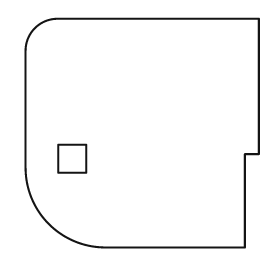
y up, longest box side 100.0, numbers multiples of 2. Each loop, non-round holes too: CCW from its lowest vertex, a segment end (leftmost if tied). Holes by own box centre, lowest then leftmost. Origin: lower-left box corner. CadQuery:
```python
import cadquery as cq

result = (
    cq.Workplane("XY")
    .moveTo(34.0, 0.0)
    .lineTo(94.0, 0.0)
    .lineTo(94.0, 40.0)
    .lineTo(100.0, 40.0)
    .lineTo(100.0, 98.0)
    .lineTo(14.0, 98.0)
    .threePointArc((4.0, 94.0), (0.0, 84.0))
    .lineTo(0.0, 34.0)
    .threePointArc((10.0, 10.0), (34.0, 0.0))
    .close()
    .moveTo(14.0, 32.0)
    .lineTo(26.0, 32.0)
    .lineTo(26.0, 44.0)
    .lineTo(14.0, 44.0)
    .close()
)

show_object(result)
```